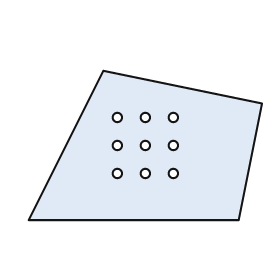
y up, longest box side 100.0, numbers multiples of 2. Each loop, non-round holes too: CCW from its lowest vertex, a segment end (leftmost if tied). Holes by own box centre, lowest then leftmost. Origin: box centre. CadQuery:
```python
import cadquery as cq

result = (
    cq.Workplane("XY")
    .moveTo(-50.0, -32.0)
    .lineTo(40.0, -32.0)
    .lineTo(50.0, 18.0)
    .lineTo(-18.0, 32.0)
    .close()
    .moveTo(-12.0, -12.0)
    .circle(2.0)
    .moveTo(0.0, -12.0)
    .circle(2.0)
    .moveTo(12.0, -12.0)
    .circle(2.0)
    .moveTo(-12.0, 0.0)
    .circle(2.0)
    .moveTo(0.0, 0.0)
    .circle(2.0)
    .moveTo(12.0, 0.0)
    .circle(2.0)
    .moveTo(-12.0, 12.0)
    .circle(2.0)
    .moveTo(0.0, 12.0)
    .circle(2.0)
    .moveTo(12.0, 12.0)
    .circle(2.0)
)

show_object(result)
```